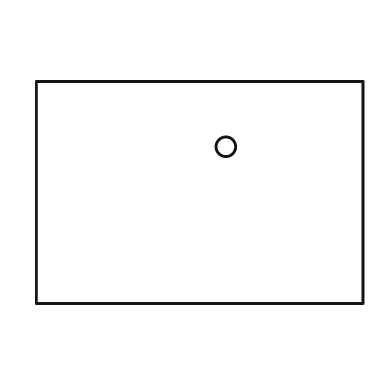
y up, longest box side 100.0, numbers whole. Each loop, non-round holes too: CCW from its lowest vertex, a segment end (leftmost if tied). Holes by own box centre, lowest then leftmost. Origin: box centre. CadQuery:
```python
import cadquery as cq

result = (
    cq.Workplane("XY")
    .moveTo(-50.0, -34.0)
    .lineTo(50.0, -34.0)
    .lineTo(50.0, 34.0)
    .lineTo(-50.0, 34.0)
    .close()
    .moveTo(8.0, 14.0)
    .circle(3.0)
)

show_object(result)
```